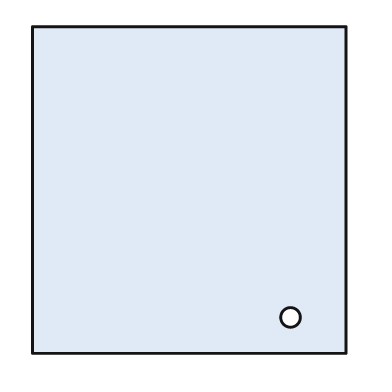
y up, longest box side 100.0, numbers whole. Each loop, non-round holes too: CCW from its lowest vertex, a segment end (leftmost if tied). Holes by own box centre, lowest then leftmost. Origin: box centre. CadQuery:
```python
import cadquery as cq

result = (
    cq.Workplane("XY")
    .moveTo(-48.0, -50.0)
    .lineTo(48.0, -50.0)
    .lineTo(48.0, 50.0)
    .lineTo(-48.0, 50.0)
    .close()
    .moveTo(31.0, -39.0)
    .circle(3.0)
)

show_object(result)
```